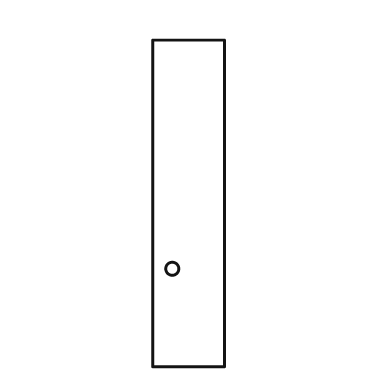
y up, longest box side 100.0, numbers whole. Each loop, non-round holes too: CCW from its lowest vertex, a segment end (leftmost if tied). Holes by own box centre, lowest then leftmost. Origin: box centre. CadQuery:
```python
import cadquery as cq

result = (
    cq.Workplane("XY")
    .moveTo(-11.0, -50.0)
    .lineTo(11.0, -50.0)
    .lineTo(11.0, 50.0)
    .lineTo(-11.0, 50.0)
    .close()
    .moveTo(-5.0, -20.0)
    .circle(2.0)
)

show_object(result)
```